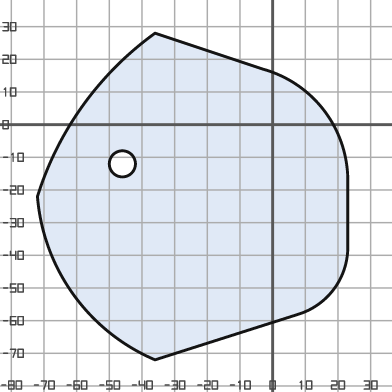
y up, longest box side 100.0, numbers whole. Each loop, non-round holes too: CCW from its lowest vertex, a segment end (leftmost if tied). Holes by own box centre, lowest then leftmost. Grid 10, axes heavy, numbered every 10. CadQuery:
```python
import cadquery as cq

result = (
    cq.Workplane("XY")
    .moveTo(-36.0, -72.0)
    .lineTo(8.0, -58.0)
    .threePointArc((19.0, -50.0), (23.0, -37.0))
    .lineTo(23.0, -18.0)
    .threePointArc((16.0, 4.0), (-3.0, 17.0))
    .lineTo(-36.0, 28.0)
    .threePointArc((-58.0, 6.0), (-72.0, -22.0))
    .threePointArc((-61.0, -52.0), (-36.0, -72.0))
    .close()
    .moveTo(-46.0, -12.0)
    .circle(4.0)
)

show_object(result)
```